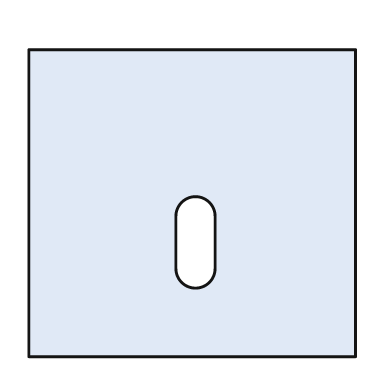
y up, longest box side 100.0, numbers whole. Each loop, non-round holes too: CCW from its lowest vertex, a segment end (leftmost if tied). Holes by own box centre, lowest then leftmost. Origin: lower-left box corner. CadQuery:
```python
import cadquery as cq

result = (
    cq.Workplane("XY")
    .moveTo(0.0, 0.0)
    .lineTo(100.0, 0.0)
    .lineTo(100.0, 94.0)
    .lineTo(0.0, 94.0)
    .close()
    .moveTo(45.0, 27.0)
    .threePointArc((51.0, 21.0), (57.0, 27.0))
    .lineTo(57.0, 43.0)
    .threePointArc((51.0, 49.0), (45.0, 43.0))
    .close()
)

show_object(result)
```